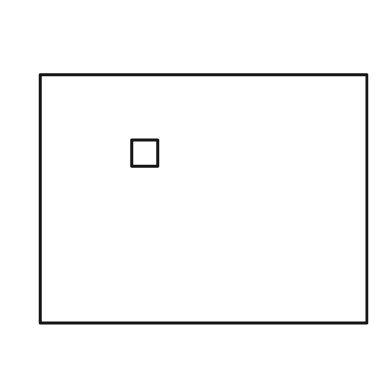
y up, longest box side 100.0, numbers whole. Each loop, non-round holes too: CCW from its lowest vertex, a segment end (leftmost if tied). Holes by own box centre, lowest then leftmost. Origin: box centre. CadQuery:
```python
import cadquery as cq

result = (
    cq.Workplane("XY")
    .moveTo(-50.0, -38.0)
    .lineTo(50.0, -38.0)
    .lineTo(50.0, 38.0)
    .lineTo(-50.0, 38.0)
    .close()
    .moveTo(-22.0, 10.0)
    .lineTo(-14.0, 10.0)
    .lineTo(-14.0, 18.0)
    .lineTo(-22.0, 18.0)
    .close()
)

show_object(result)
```